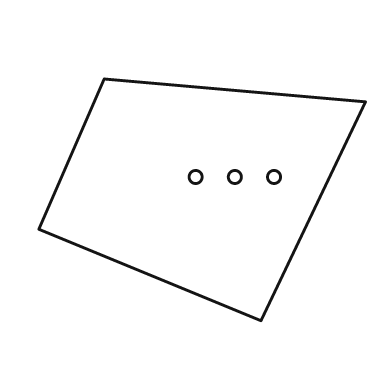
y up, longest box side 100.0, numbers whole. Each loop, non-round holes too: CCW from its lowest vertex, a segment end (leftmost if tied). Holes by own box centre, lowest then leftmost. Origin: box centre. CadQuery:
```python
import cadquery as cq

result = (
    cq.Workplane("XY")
    .moveTo(18.0, -37.0)
    .lineTo(50.0, 30.0)
    .lineTo(-30.0, 37.0)
    .lineTo(-50.0, -9.0)
    .close()
    .moveTo(-2.0, 7.0)
    .circle(2.0)
    .moveTo(10.0, 7.0)
    .circle(2.0)
    .moveTo(22.0, 7.0)
    .circle(2.0)
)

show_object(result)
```